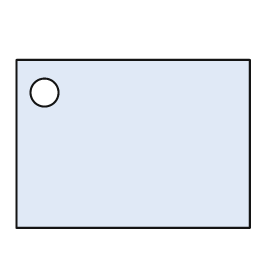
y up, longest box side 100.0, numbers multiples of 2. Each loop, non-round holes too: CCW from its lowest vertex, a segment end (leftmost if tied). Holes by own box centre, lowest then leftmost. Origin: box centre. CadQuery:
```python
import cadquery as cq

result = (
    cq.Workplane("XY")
    .moveTo(-50.0, -36.0)
    .lineTo(50.0, -36.0)
    .lineTo(50.0, 36.0)
    .lineTo(-50.0, 36.0)
    .close()
    .moveTo(-38.0, 22.0)
    .circle(6.0)
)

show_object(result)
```